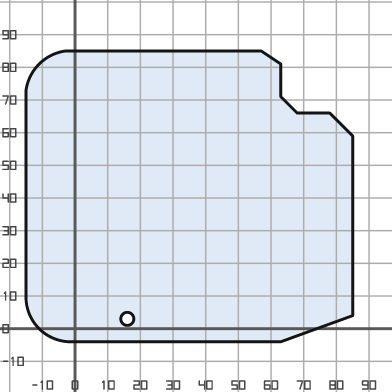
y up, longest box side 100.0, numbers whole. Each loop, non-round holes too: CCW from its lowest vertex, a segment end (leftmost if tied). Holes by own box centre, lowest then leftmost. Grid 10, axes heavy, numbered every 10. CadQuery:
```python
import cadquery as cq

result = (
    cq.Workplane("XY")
    .moveTo(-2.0, -4.0)
    .lineTo(63.0, -4.0)
    .lineTo(85.0, 4.0)
    .lineTo(85.0, 59.0)
    .lineTo(78.0, 66.0)
    .lineTo(68.0, 66.0)
    .lineTo(63.0, 71.0)
    .lineTo(63.0, 81.0)
    .lineTo(57.0, 85.0)
    .lineTo(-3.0, 85.0)
    .threePointArc((-11.0, 81.0), (-15.0, 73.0))
    .lineTo(-15.0, 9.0)
    .threePointArc((-11.0, 0.0), (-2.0, -4.0))
    .close()
    .moveTo(16.0, 3.0)
    .circle(2.0)
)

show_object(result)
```